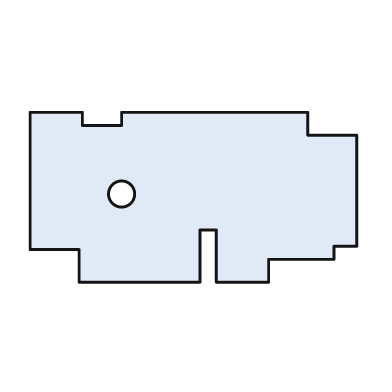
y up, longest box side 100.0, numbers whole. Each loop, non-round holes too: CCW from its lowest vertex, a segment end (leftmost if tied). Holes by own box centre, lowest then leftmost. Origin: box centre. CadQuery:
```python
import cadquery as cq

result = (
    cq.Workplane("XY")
    .moveTo(-35.0, -26.0)
    .lineTo(2.0, -26.0)
    .lineTo(2.0, -10.0)
    .lineTo(7.0, -10.0)
    .lineTo(7.0, -26.0)
    .lineTo(23.0, -26.0)
    .lineTo(23.0, -19.0)
    .lineTo(43.0, -19.0)
    .lineTo(43.0, -15.0)
    .lineTo(50.0, -15.0)
    .lineTo(50.0, 19.0)
    .lineTo(35.0, 19.0)
    .lineTo(35.0, 26.0)
    .lineTo(-22.0, 26.0)
    .lineTo(-22.0, 22.0)
    .lineTo(-34.0, 22.0)
    .lineTo(-34.0, 26.0)
    .lineTo(-50.0, 26.0)
    .lineTo(-50.0, -16.0)
    .lineTo(-35.0, -16.0)
    .close()
    .moveTo(-22.0, 1.0)
    .circle(4.0)
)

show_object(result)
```